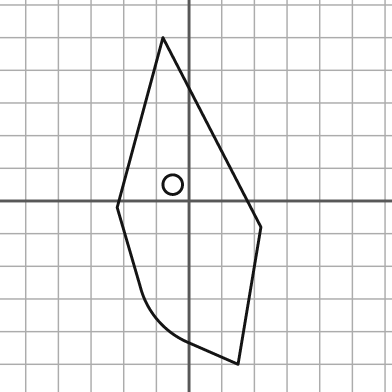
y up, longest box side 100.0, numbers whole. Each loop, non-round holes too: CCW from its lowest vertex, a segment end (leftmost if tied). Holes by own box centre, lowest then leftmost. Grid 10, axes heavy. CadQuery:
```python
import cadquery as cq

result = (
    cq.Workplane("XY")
    .moveTo(15.0, -50.0)
    .lineTo(22.0, -8.0)
    .lineTo(-8.0, 50.0)
    .lineTo(-22.0, -2.0)
    .lineTo(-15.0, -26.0)
    .threePointArc((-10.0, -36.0), (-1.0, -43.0))
    .close()
    .moveTo(-5.0, 5.0)
    .circle(3.0)
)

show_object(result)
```